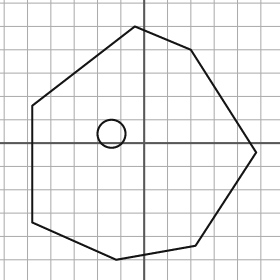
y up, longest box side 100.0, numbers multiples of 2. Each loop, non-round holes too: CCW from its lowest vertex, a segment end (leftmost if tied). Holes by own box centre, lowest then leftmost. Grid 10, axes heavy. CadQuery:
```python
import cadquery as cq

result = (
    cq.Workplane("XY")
    .moveTo(-12.0, -50.0)
    .lineTo(22.0, -44.0)
    .lineTo(48.0, -4.0)
    .lineTo(20.0, 40.0)
    .lineTo(-4.0, 50.0)
    .lineTo(-48.0, 16.0)
    .lineTo(-48.0, -34.0)
    .close()
    .moveTo(-14.0, 4.0)
    .circle(6.0)
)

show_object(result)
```